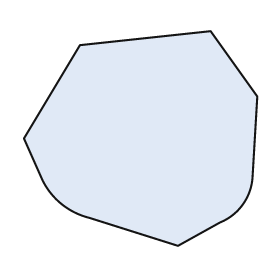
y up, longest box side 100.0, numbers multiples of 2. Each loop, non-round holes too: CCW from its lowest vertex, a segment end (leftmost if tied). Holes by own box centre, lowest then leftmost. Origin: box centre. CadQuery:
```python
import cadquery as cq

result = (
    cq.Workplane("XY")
    .moveTo(16.0, -46.0)
    .lineTo(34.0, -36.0)
    .threePointArc((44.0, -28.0), (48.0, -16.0))
    .lineTo(50.0, 18.0)
    .lineTo(30.0, 46.0)
    .lineTo(-26.0, 40.0)
    .lineTo(-50.0, 0.0)
    .lineTo(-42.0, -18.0)
    .threePointArc((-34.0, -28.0), (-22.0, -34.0))
    .close()
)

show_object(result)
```